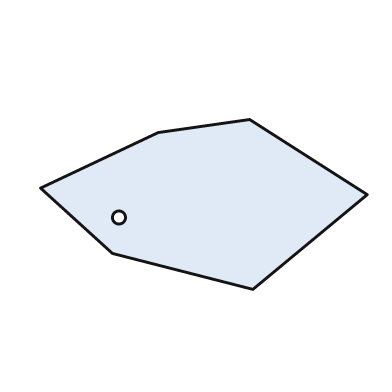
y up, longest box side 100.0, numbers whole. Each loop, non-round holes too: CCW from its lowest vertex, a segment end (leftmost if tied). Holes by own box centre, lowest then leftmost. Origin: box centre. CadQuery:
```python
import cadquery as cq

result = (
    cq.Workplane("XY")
    .moveTo(15.0, -26.0)
    .lineTo(50.0, 3.0)
    .lineTo(14.0, 26.0)
    .lineTo(-14.0, 22.0)
    .lineTo(-50.0, 5.0)
    .lineTo(-28.0, -15.0)
    .close()
    .moveTo(-26.0, -4.0)
    .circle(2.0)
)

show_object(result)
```